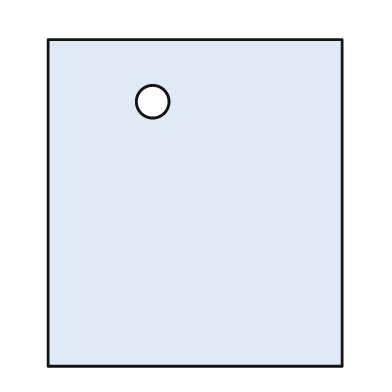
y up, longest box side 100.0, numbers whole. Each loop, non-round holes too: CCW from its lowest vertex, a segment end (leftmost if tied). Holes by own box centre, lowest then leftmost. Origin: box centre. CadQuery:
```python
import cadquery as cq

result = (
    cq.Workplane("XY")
    .moveTo(-45.0, -50.0)
    .lineTo(45.0, -50.0)
    .lineTo(45.0, 50.0)
    .lineTo(-45.0, 50.0)
    .close()
    .moveTo(-13.0, 31.0)
    .circle(5.0)
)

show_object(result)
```